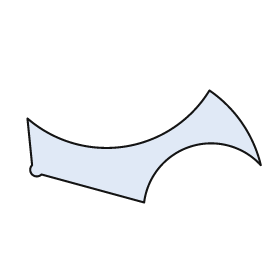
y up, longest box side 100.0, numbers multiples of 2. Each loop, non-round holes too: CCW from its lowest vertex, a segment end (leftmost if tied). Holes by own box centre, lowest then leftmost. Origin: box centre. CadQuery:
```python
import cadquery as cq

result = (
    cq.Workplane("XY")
    .moveTo(0.0, -24.0)
    .threePointArc((20.0, 0.0), (50.0, -8.0))
    .threePointArc((42.0, 10.0), (28.0, 24.0))
    .threePointArc((-8.0, 0.0), (-50.0, 12.0))
    .lineTo(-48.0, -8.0)
    .threePointArc((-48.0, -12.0), (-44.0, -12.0))
    .close()
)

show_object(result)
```